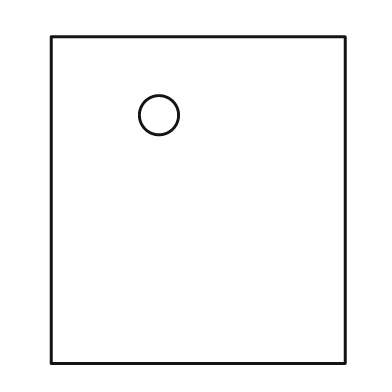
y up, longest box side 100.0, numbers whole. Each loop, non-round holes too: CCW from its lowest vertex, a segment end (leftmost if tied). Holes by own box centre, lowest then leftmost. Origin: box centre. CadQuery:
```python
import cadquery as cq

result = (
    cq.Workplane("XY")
    .moveTo(-45.0, -50.0)
    .lineTo(45.0, -50.0)
    .lineTo(45.0, 50.0)
    .lineTo(-45.0, 50.0)
    .close()
    .moveTo(-12.0, 26.0)
    .circle(6.0)
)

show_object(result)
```